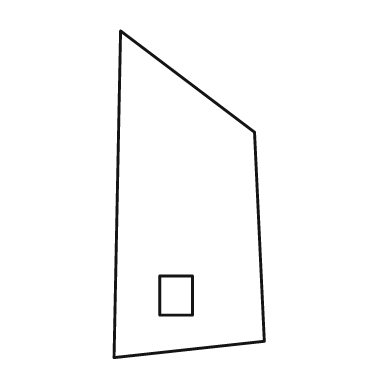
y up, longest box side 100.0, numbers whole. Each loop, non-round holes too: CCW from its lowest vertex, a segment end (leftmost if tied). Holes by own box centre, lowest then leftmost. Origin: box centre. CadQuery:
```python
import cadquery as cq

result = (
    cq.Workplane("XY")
    .moveTo(-23.0, -50.0)
    .lineTo(23.0, -45.0)
    .lineTo(20.0, 19.0)
    .lineTo(-21.0, 50.0)
    .close()
    .moveTo(-9.0, -37.0)
    .lineTo(1.0, -37.0)
    .lineTo(1.0, -25.0)
    .lineTo(-9.0, -25.0)
    .close()
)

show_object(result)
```